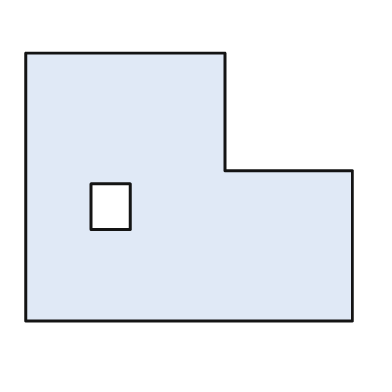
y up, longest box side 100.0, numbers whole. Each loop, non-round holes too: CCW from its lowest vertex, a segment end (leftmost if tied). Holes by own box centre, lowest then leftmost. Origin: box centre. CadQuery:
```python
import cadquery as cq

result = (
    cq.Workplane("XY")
    .moveTo(-50.0, -41.0)
    .lineTo(50.0, -41.0)
    .lineTo(50.0, 5.0)
    .lineTo(11.0, 5.0)
    .lineTo(11.0, 41.0)
    .lineTo(-50.0, 41.0)
    .close()
    .moveTo(-30.0, -13.0)
    .lineTo(-18.0, -13.0)
    .lineTo(-18.0, 1.0)
    .lineTo(-30.0, 1.0)
    .close()
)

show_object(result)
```